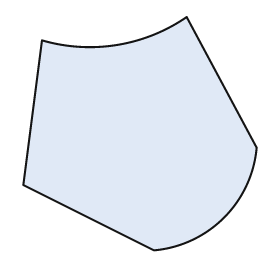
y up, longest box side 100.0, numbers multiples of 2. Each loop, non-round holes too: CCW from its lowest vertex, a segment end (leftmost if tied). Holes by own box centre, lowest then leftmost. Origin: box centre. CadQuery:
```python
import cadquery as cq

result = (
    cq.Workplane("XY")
    .moveTo(6.0, -50.0)
    .threePointArc((36.0, -36.0), (50.0, -6.0))
    .lineTo(20.0, 50.0)
    .threePointArc((-10.0, 38.0), (-42.0, 40.0))
    .lineTo(-50.0, -22.0)
    .close()
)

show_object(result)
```